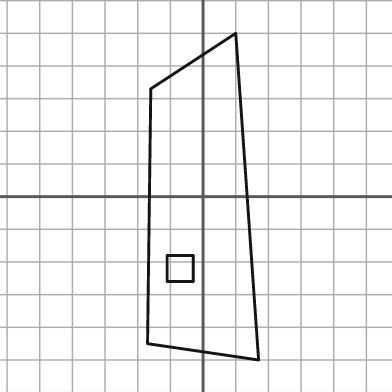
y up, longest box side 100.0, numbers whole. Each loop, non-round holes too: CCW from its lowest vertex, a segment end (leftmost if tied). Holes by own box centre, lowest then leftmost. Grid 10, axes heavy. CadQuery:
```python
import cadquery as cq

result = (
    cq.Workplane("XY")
    .moveTo(17.0, -50.0)
    .lineTo(10.0, 50.0)
    .lineTo(-16.0, 33.0)
    .lineTo(-17.0, -45.0)
    .close()
    .moveTo(-11.0, -26.0)
    .lineTo(-3.0, -26.0)
    .lineTo(-3.0, -18.0)
    .lineTo(-11.0, -18.0)
    .close()
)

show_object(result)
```